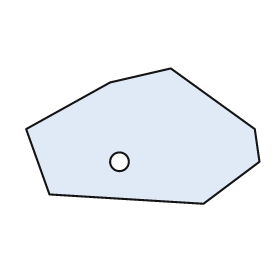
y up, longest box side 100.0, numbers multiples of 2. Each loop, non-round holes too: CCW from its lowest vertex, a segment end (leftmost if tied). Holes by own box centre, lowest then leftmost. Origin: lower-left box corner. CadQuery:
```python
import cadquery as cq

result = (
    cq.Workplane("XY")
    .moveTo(76.0, 0.0)
    .lineTo(100.0, 18.0)
    .lineTo(98.0, 32.0)
    .lineTo(62.0, 58.0)
    .lineTo(36.0, 52.0)
    .lineTo(0.0, 32.0)
    .lineTo(10.0, 4.0)
    .close()
    .moveTo(40.0, 18.0)
    .circle(4.0)
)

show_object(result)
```